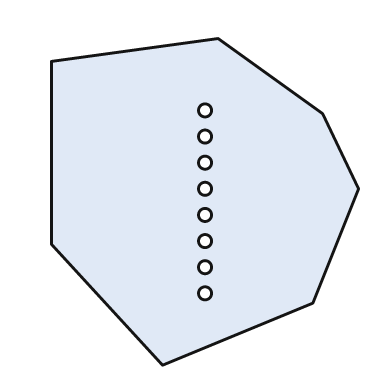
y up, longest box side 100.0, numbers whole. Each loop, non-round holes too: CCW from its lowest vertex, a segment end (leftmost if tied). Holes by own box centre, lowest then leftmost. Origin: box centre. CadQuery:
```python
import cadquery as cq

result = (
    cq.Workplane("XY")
    .moveTo(-13.0, -50.0)
    .lineTo(33.0, -31.0)
    .lineTo(47.0, 4.0)
    .lineTo(36.0, 27.0)
    .lineTo(4.0, 50.0)
    .lineTo(-47.0, 43.0)
    .lineTo(-47.0, -13.0)
    .close()
    .moveTo(0.0, -28.0)
    .circle(2.0)
    .moveTo(0.0, -20.0)
    .circle(2.0)
    .moveTo(0.0, -12.0)
    .circle(2.0)
    .moveTo(0.0, -4.0)
    .circle(2.0)
    .moveTo(0.0, 4.0)
    .circle(2.0)
    .moveTo(0.0, 12.0)
    .circle(2.0)
    .moveTo(0.0, 20.0)
    .circle(2.0)
    .moveTo(0.0, 28.0)
    .circle(2.0)
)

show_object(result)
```